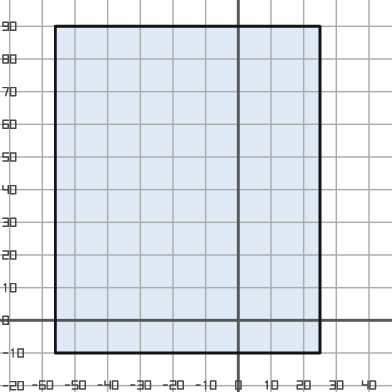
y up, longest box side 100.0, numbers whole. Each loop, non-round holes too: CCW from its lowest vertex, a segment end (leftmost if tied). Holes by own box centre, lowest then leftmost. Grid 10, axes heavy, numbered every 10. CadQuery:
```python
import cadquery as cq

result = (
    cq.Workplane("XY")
    .moveTo(-56.0, -10.0)
    .lineTo(25.0, -10.0)
    .lineTo(25.0, 90.0)
    .lineTo(-56.0, 90.0)
    .close()
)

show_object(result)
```